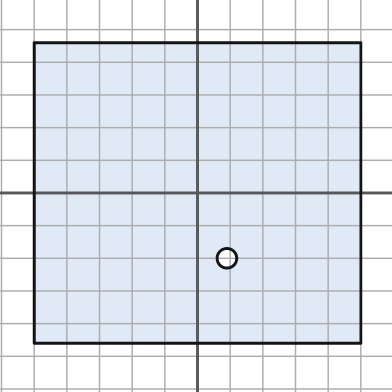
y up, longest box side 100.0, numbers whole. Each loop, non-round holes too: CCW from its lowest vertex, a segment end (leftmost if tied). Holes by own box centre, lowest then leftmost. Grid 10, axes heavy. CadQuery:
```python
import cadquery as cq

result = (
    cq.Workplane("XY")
    .moveTo(-50.0, -46.0)
    .lineTo(50.0, -46.0)
    .lineTo(50.0, 46.0)
    .lineTo(-50.0, 46.0)
    .close()
    .moveTo(9.0, -20.0)
    .circle(3.0)
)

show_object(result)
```